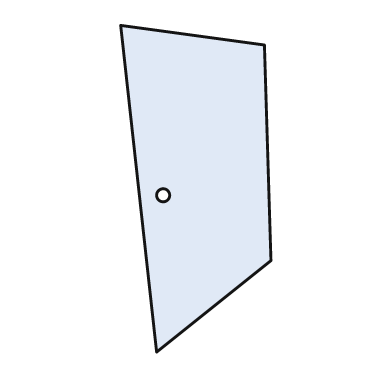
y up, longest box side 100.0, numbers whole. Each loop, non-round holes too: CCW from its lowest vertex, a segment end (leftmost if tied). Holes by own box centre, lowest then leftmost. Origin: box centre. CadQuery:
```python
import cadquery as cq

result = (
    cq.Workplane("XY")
    .moveTo(-12.0, -50.0)
    .lineTo(23.0, -22.0)
    .lineTo(21.0, 44.0)
    .lineTo(-23.0, 50.0)
    .close()
    .moveTo(-10.0, -2.0)
    .circle(2.0)
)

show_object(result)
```